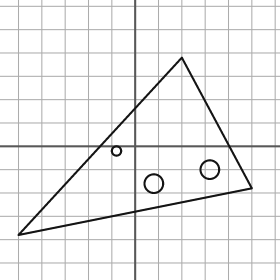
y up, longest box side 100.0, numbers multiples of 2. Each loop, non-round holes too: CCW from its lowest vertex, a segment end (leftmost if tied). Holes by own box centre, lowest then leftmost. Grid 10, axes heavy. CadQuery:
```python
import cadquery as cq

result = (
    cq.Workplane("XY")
    .moveTo(-50.0, -38.0)
    .lineTo(50.0, -18.0)
    .lineTo(20.0, 38.0)
    .close()
    .moveTo(8.0, -16.0)
    .circle(4.0)
    .moveTo(32.0, -10.0)
    .circle(4.0)
    .moveTo(-8.0, -2.0)
    .circle(2.0)
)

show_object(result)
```